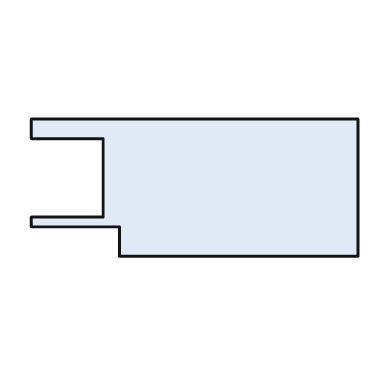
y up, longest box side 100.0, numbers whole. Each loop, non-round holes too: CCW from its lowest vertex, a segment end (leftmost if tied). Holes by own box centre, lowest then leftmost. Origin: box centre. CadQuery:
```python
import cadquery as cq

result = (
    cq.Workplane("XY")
    .moveTo(-23.0, -21.0)
    .lineTo(50.0, -21.0)
    .lineTo(50.0, 21.0)
    .lineTo(-50.0, 21.0)
    .lineTo(-50.0, 15.0)
    .lineTo(-28.0, 15.0)
    .lineTo(-28.0, -9.0)
    .lineTo(-50.0, -9.0)
    .lineTo(-50.0, -12.0)
    .lineTo(-23.0, -12.0)
    .close()
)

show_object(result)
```